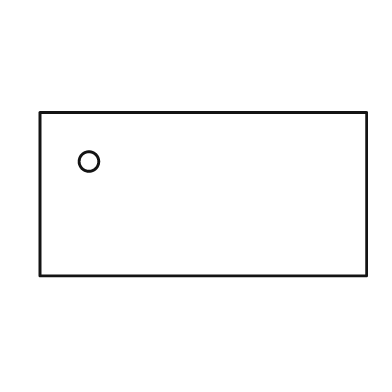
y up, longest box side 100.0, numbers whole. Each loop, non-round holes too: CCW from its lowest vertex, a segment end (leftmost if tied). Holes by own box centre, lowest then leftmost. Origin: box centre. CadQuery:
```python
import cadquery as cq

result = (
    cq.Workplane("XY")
    .moveTo(-50.0, -25.0)
    .lineTo(50.0, -25.0)
    .lineTo(50.0, 25.0)
    .lineTo(-50.0, 25.0)
    .close()
    .moveTo(-35.0, 10.0)
    .circle(3.0)
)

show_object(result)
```